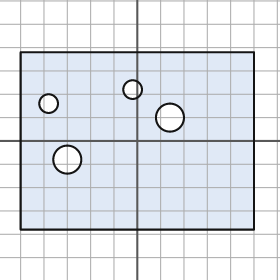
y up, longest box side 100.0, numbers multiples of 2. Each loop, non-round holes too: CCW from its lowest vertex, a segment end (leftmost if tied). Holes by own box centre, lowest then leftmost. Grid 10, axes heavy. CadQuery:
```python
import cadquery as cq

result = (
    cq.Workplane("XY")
    .moveTo(-50.0, -38.0)
    .lineTo(50.0, -38.0)
    .lineTo(50.0, 38.0)
    .lineTo(-50.0, 38.0)
    .close()
    .moveTo(-30.0, -8.0)
    .circle(6.0)
    .moveTo(14.0, 10.0)
    .circle(6.0)
    .moveTo(-38.0, 16.0)
    .circle(4.0)
    .moveTo(-2.0, 22.0)
    .circle(4.0)
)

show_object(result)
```